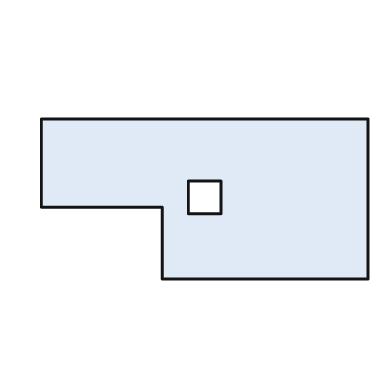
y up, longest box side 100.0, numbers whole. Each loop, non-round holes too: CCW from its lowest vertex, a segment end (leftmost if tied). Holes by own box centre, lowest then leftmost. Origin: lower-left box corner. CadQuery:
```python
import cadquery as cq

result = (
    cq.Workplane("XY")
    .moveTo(37.0, 0.0)
    .lineTo(100.0, 0.0)
    .lineTo(100.0, 49.0)
    .lineTo(0.0, 49.0)
    .lineTo(0.0, 22.0)
    .lineTo(37.0, 22.0)
    .close()
    .moveTo(45.0, 20.0)
    .lineTo(55.0, 20.0)
    .lineTo(55.0, 30.0)
    .lineTo(45.0, 30.0)
    .close()
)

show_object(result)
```